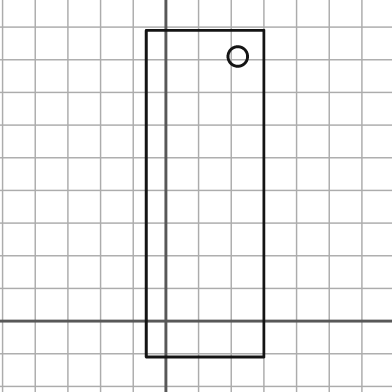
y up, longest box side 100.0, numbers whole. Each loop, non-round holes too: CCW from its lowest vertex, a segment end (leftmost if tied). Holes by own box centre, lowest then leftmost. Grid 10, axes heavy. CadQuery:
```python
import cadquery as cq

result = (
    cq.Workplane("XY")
    .moveTo(-6.0, -11.0)
    .lineTo(30.0, -11.0)
    .lineTo(30.0, 89.0)
    .lineTo(-6.0, 89.0)
    .close()
    .moveTo(22.0, 81.0)
    .circle(3.0)
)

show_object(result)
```